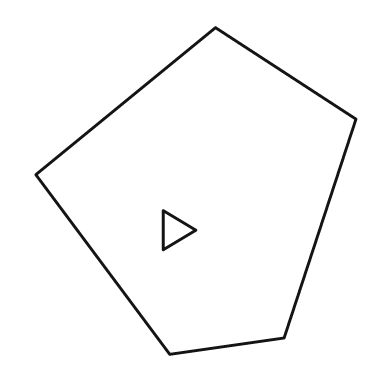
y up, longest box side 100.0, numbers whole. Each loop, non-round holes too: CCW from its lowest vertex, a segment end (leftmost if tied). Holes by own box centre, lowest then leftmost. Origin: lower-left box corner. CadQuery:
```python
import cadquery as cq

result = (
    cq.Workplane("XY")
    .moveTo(41.0, 0.0)
    .lineTo(76.0, 5.0)
    .lineTo(98.0, 72.0)
    .lineTo(55.0, 100.0)
    .lineTo(0.0, 55.0)
    .close()
    .moveTo(39.0, 32.0)
    .lineTo(49.0, 38.0)
    .lineTo(39.0, 44.0)
    .close()
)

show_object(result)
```